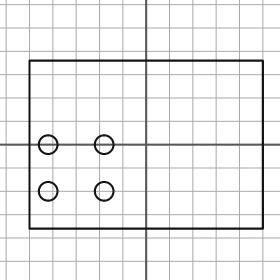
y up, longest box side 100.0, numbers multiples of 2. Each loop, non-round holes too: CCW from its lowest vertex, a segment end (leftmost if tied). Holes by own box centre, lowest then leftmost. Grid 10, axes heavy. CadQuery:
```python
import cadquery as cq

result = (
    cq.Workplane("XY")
    .moveTo(-50.0, -36.0)
    .lineTo(50.0, -36.0)
    .lineTo(50.0, 36.0)
    .lineTo(-50.0, 36.0)
    .close()
    .moveTo(-42.0, -20.0)
    .circle(4.0)
    .moveTo(-18.0, -20.0)
    .circle(4.0)
    .moveTo(-42.0, 0.0)
    .circle(4.0)
    .moveTo(-18.0, 0.0)
    .circle(4.0)
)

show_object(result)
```